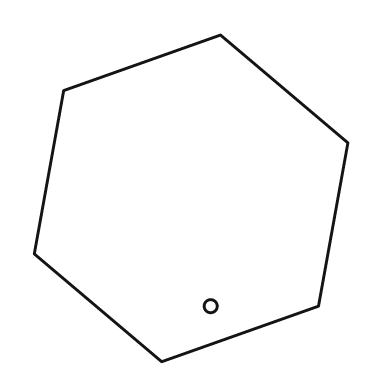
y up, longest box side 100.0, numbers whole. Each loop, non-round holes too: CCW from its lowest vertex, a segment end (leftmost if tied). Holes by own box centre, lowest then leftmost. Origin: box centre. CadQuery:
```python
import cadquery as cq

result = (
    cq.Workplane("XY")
    .moveTo(-9.0, -50.0)
    .lineTo(39.0, -33.0)
    .lineTo(48.0, 17.0)
    .lineTo(9.0, 50.0)
    .lineTo(-39.0, 33.0)
    .lineTo(-48.0, -17.0)
    .close()
    .moveTo(6.0, -33.0)
    .circle(2.0)
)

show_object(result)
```